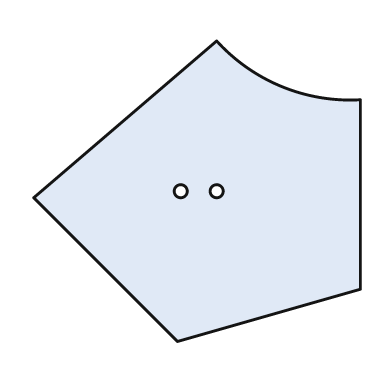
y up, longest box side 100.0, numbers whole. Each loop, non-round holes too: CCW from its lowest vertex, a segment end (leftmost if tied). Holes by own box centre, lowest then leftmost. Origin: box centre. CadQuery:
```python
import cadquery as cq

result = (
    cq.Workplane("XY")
    .moveTo(-6.0, -46.0)
    .lineTo(50.0, -30.0)
    .lineTo(50.0, 28.0)
    .threePointArc((26.0, 32.0), (6.0, 46.0))
    .lineTo(-50.0, -2.0)
    .close()
    .moveTo(-5.0, 0.0)
    .circle(2.0)
    .moveTo(6.0, 0.0)
    .circle(2.0)
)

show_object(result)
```